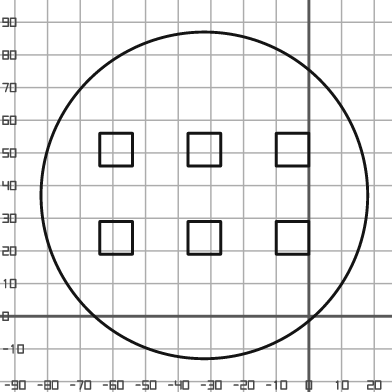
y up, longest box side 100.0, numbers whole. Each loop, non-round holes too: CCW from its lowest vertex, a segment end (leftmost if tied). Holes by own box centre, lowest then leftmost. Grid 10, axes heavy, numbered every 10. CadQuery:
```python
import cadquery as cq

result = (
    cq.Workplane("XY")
    .moveTo(-32.0, 37.0)
    .circle(50.0)
    .moveTo(-64.0, 19.0)
    .lineTo(-54.0, 19.0)
    .lineTo(-54.0, 29.0)
    .lineTo(-64.0, 29.0)
    .close()
    .moveTo(-37.0, 19.0)
    .lineTo(-27.0, 19.0)
    .lineTo(-27.0, 29.0)
    .lineTo(-37.0, 29.0)
    .close()
    .moveTo(-10.0, 19.0)
    .lineTo(0.0, 19.0)
    .lineTo(0.0, 29.0)
    .lineTo(-10.0, 29.0)
    .close()
    .moveTo(-64.0, 46.0)
    .lineTo(-54.0, 46.0)
    .lineTo(-54.0, 56.0)
    .lineTo(-64.0, 56.0)
    .close()
    .moveTo(-37.0, 46.0)
    .lineTo(-27.0, 46.0)
    .lineTo(-27.0, 56.0)
    .lineTo(-37.0, 56.0)
    .close()
    .moveTo(-10.0, 46.0)
    .lineTo(0.0, 46.0)
    .lineTo(0.0, 56.0)
    .lineTo(-10.0, 56.0)
    .close()
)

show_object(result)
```